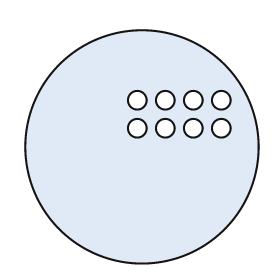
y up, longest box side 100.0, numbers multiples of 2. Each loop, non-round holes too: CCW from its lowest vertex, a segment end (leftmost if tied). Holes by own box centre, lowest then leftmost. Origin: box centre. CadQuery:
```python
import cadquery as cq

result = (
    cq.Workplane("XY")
    .moveTo(0.0, 0.0)
    .circle(50.0)
    .moveTo(-2.0, 8.0)
    .circle(4.0)
    .moveTo(10.0, 8.0)
    .circle(4.0)
    .moveTo(22.0, 8.0)
    .circle(4.0)
    .moveTo(34.0, 8.0)
    .circle(4.0)
    .moveTo(-2.0, 20.0)
    .circle(4.0)
    .moveTo(10.0, 20.0)
    .circle(4.0)
    .moveTo(22.0, 20.0)
    .circle(4.0)
    .moveTo(34.0, 20.0)
    .circle(4.0)
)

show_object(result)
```